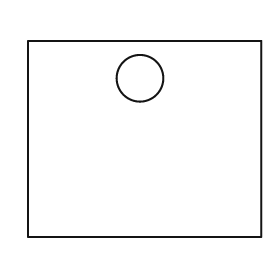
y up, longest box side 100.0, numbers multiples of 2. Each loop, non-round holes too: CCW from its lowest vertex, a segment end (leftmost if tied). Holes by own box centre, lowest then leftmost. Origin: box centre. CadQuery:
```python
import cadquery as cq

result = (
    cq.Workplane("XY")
    .moveTo(-50.0, -42.0)
    .lineTo(50.0, -42.0)
    .lineTo(50.0, 42.0)
    .lineTo(-50.0, 42.0)
    .close()
    .moveTo(-2.0, 26.0)
    .circle(10.0)
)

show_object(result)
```